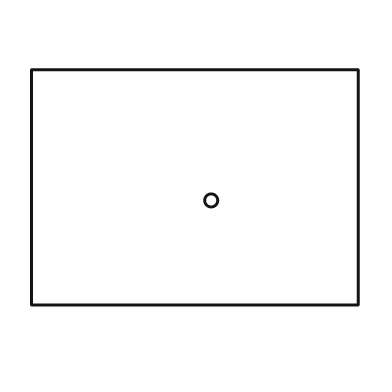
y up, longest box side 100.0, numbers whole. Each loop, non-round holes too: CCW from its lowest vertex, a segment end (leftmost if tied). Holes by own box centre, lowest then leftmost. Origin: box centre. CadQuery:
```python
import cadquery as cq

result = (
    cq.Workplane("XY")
    .moveTo(-50.0, -36.0)
    .lineTo(50.0, -36.0)
    .lineTo(50.0, 36.0)
    .lineTo(-50.0, 36.0)
    .close()
    .moveTo(5.0, -4.0)
    .circle(2.0)
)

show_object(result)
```